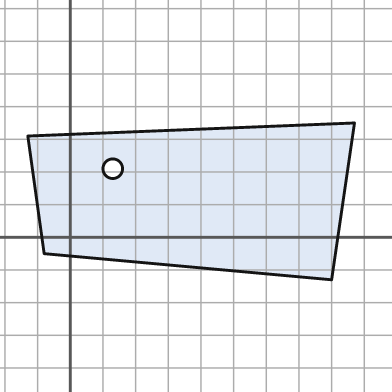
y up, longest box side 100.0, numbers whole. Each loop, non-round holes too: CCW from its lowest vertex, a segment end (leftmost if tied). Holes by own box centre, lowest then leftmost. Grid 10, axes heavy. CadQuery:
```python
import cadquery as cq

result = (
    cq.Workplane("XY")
    .moveTo(80.0, -13.0)
    .lineTo(87.0, 35.0)
    .lineTo(-13.0, 31.0)
    .lineTo(-8.0, -5.0)
    .close()
    .moveTo(13.0, 21.0)
    .circle(3.0)
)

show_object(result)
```